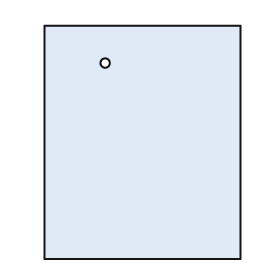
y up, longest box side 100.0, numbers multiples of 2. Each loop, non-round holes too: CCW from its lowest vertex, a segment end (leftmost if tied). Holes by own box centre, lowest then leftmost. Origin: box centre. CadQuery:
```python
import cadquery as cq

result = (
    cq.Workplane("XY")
    .moveTo(-42.0, -50.0)
    .lineTo(42.0, -50.0)
    .lineTo(42.0, 50.0)
    .lineTo(-42.0, 50.0)
    .close()
    .moveTo(-16.0, 34.0)
    .circle(2.0)
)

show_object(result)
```